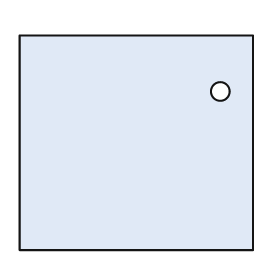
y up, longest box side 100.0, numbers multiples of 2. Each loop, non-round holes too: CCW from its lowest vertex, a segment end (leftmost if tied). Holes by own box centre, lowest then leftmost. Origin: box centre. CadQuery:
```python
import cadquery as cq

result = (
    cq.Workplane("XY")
    .moveTo(-50.0, -46.0)
    .lineTo(50.0, -46.0)
    .lineTo(50.0, 46.0)
    .lineTo(-50.0, 46.0)
    .close()
    .moveTo(36.0, 22.0)
    .circle(4.0)
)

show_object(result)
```